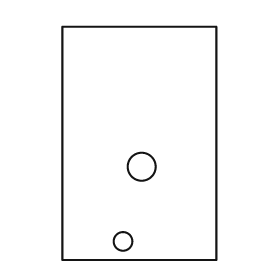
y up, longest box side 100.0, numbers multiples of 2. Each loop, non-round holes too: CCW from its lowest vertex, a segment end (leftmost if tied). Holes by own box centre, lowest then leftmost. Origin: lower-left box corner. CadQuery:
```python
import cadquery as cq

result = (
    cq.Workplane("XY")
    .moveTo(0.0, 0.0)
    .lineTo(66.0, 0.0)
    .lineTo(66.0, 100.0)
    .lineTo(0.0, 100.0)
    .close()
    .moveTo(26.0, 8.0)
    .circle(4.0)
    .moveTo(34.0, 40.0)
    .circle(6.0)
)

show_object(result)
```